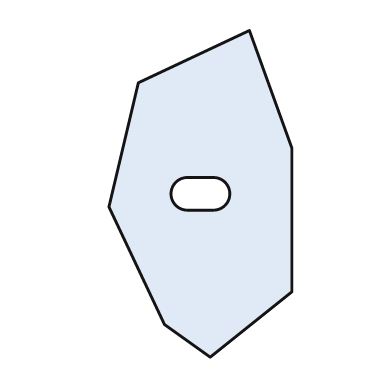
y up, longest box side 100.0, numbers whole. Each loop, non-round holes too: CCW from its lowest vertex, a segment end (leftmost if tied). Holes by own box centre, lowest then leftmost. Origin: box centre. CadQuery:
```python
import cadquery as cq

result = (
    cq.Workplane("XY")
    .moveTo(3.0, -50.0)
    .lineTo(28.0, -30.0)
    .lineTo(28.0, 14.0)
    .lineTo(15.0, 50.0)
    .lineTo(-19.0, 34.0)
    .lineTo(-28.0, -4.0)
    .lineTo(-11.0, -40.0)
    .close()
    .moveTo(-4.0, -5.0)
    .lineTo(4.0, -5.0)
    .threePointArc((9.0, 0.0), (4.0, 5.0))
    .lineTo(-4.0, 5.0)
    .threePointArc((-9.0, 0.0), (-4.0, -5.0))
    .close()
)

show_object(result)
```